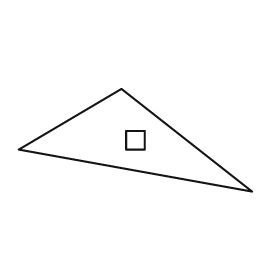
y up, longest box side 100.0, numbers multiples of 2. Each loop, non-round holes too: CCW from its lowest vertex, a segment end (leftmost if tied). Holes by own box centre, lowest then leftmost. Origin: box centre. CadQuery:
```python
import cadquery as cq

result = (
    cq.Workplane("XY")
    .moveTo(50.0, -22.0)
    .lineTo(-6.0, 22.0)
    .lineTo(-50.0, -4.0)
    .close()
    .moveTo(-4.0, -4.0)
    .lineTo(4.0, -4.0)
    .lineTo(4.0, 4.0)
    .lineTo(-4.0, 4.0)
    .close()
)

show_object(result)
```